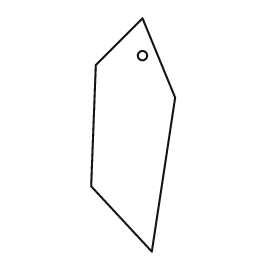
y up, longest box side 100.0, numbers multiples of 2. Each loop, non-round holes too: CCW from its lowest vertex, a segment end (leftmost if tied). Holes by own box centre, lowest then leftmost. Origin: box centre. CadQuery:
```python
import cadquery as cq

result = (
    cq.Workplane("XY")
    .moveTo(8.0, -50.0)
    .lineTo(18.0, 16.0)
    .lineTo(4.0, 50.0)
    .lineTo(-16.0, 30.0)
    .lineTo(-18.0, -22.0)
    .close()
    .moveTo(4.0, 34.0)
    .circle(2.0)
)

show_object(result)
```